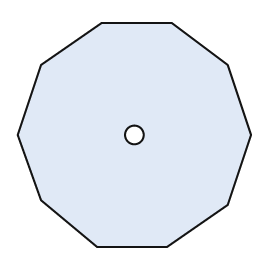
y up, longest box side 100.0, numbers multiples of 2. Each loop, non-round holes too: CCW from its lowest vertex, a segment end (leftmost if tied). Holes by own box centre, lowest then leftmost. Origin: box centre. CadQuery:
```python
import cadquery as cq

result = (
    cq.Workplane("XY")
    .moveTo(-16.0, -48.0)
    .lineTo(14.0, -48.0)
    .lineTo(40.0, -30.0)
    .lineTo(50.0, 0.0)
    .lineTo(40.0, 30.0)
    .lineTo(16.0, 48.0)
    .lineTo(-14.0, 48.0)
    .lineTo(-40.0, 30.0)
    .lineTo(-50.0, 0.0)
    .lineTo(-40.0, -28.0)
    .close()
    .moveTo(0.0, 0.0)
    .circle(4.0)
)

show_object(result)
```